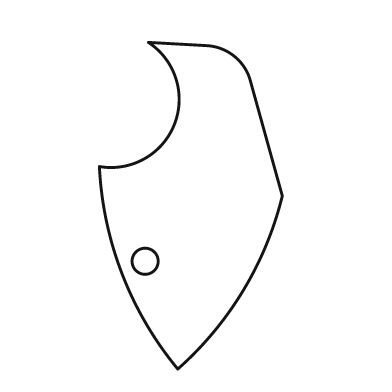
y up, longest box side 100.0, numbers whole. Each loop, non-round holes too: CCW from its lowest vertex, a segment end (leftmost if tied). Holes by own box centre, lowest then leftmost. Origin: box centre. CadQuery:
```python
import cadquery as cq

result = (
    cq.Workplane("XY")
    .moveTo(-4.0, -50.0)
    .threePointArc((16.0, -26.0), (28.0, 3.0))
    .lineTo(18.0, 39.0)
    .threePointArc((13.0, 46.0), (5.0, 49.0))
    .lineTo(-13.0, 50.0)
    .threePointArc((-5.0, 25.0), (-28.0, 12.0))
    .threePointArc((-21.0, -21.0), (-4.0, -50.0))
    .close()
    .moveTo(-14.0, -17.0)
    .circle(4.0)
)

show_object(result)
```